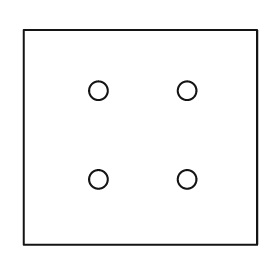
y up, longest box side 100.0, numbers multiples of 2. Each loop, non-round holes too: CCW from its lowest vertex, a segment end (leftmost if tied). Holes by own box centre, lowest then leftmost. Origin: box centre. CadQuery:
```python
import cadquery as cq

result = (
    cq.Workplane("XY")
    .moveTo(-50.0, -46.0)
    .lineTo(50.0, -46.0)
    .lineTo(50.0, 46.0)
    .lineTo(-50.0, 46.0)
    .close()
    .moveTo(-18.0, -18.0)
    .circle(4.0)
    .moveTo(20.0, -18.0)
    .circle(4.0)
    .moveTo(-18.0, 20.0)
    .circle(4.0)
    .moveTo(20.0, 20.0)
    .circle(4.0)
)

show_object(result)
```